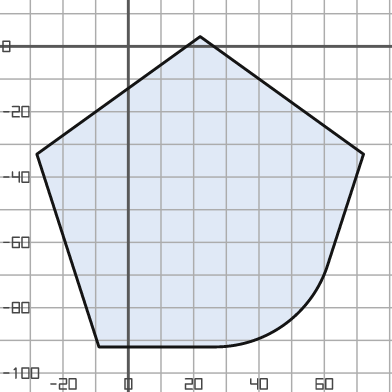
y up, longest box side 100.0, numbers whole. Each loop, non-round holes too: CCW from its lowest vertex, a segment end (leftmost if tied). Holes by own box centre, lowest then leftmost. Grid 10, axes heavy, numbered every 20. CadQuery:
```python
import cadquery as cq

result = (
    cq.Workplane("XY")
    .moveTo(-9.0, -92.0)
    .lineTo(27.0, -92.0)
    .threePointArc((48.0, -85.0), (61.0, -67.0))
    .lineTo(72.0, -33.0)
    .lineTo(22.0, 3.0)
    .lineTo(-28.0, -33.0)
    .close()
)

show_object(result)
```